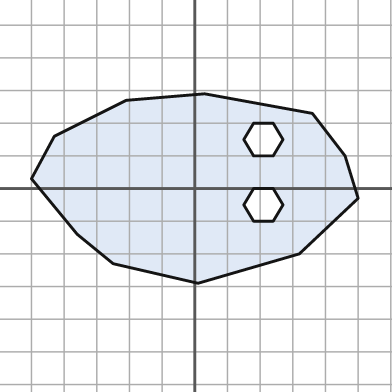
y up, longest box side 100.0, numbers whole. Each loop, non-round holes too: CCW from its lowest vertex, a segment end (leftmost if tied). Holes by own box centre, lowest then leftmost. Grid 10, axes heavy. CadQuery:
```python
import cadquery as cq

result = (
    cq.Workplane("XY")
    .moveTo(1.0, -29.0)
    .lineTo(32.0, -20.0)
    .lineTo(50.0, -3.0)
    .lineTo(46.0, 10.0)
    .lineTo(36.0, 23.0)
    .lineTo(3.0, 29.0)
    .lineTo(-21.0, 27.0)
    .lineTo(-43.0, 16.0)
    .lineTo(-50.0, 3.0)
    .lineTo(-36.0, -14.0)
    .lineTo(-25.0, -23.0)
    .close()
    .moveTo(18.0, -10.0)
    .lineTo(24.0, -10.0)
    .lineTo(27.0, -5.0)
    .lineTo(24.0, 0.0)
    .lineTo(18.0, 0.0)
    .lineTo(15.0, -5.0)
    .close()
    .moveTo(18.0, 10.0)
    .lineTo(24.0, 10.0)
    .lineTo(27.0, 15.0)
    .lineTo(24.0, 20.0)
    .lineTo(18.0, 20.0)
    .lineTo(15.0, 15.0)
    .close()
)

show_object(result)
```